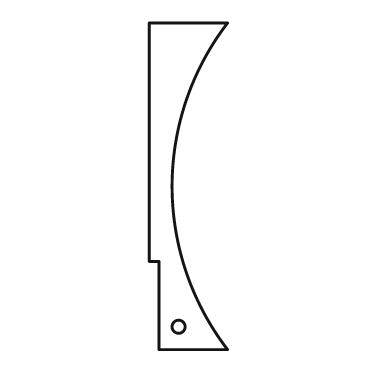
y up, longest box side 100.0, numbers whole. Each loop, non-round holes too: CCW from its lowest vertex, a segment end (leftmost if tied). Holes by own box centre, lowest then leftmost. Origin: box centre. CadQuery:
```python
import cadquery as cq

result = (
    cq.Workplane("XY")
    .moveTo(-9.0, -50.0)
    .lineTo(12.0, -50.0)
    .threePointArc((-5.0, 0.0), (12.0, 50.0))
    .lineTo(-12.0, 50.0)
    .lineTo(-12.0, -23.0)
    .lineTo(-9.0, -23.0)
    .close()
    .moveTo(-3.0, -43.0)
    .circle(2.0)
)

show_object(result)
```